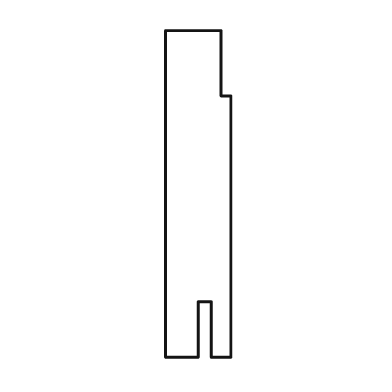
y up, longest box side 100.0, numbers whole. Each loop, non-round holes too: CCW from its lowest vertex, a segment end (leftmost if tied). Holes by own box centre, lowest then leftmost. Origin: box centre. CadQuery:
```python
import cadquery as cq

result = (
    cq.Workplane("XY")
    .moveTo(-10.0, -50.0)
    .lineTo(0.0, -50.0)
    .lineTo(0.0, -33.0)
    .lineTo(4.0, -33.0)
    .lineTo(4.0, -50.0)
    .lineTo(10.0, -50.0)
    .lineTo(10.0, 30.0)
    .lineTo(7.0, 30.0)
    .lineTo(7.0, 50.0)
    .lineTo(-10.0, 50.0)
    .close()
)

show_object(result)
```